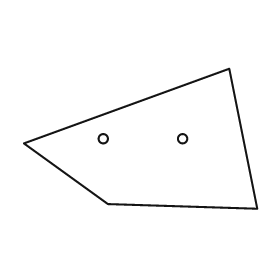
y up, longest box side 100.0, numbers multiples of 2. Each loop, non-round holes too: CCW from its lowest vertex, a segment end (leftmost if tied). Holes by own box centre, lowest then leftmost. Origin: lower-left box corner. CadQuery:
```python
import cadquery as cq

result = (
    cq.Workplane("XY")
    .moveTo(100.0, 0.0)
    .lineTo(88.0, 60.0)
    .lineTo(0.0, 28.0)
    .lineTo(36.0, 2.0)
    .close()
    .moveTo(34.0, 30.0)
    .circle(2.0)
    .moveTo(68.0, 30.0)
    .circle(2.0)
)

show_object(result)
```